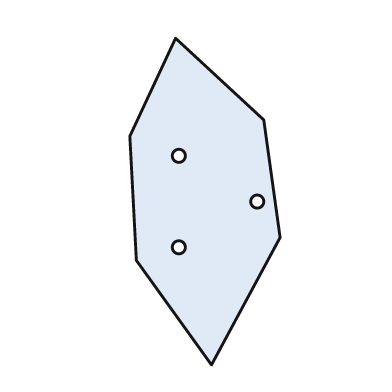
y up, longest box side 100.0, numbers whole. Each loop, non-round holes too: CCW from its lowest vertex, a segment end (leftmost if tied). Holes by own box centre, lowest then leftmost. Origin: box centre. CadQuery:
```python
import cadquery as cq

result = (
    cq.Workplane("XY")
    .moveTo(2.0, -50.0)
    .lineTo(23.0, -11.0)
    .lineTo(18.0, 25.0)
    .lineTo(-9.0, 50.0)
    .lineTo(-23.0, 20.0)
    .lineTo(-21.0, -18.0)
    .close()
    .moveTo(-8.0, -14.0)
    .circle(2.0)
    .moveTo(16.0, 0.0)
    .circle(2.0)
    .moveTo(-8.0, 14.0)
    .circle(2.0)
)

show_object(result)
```